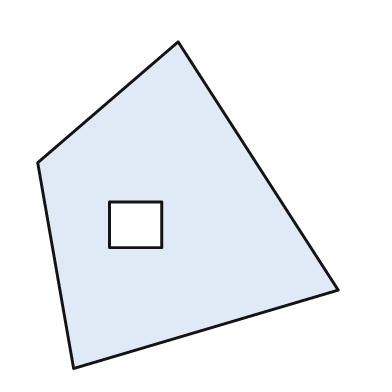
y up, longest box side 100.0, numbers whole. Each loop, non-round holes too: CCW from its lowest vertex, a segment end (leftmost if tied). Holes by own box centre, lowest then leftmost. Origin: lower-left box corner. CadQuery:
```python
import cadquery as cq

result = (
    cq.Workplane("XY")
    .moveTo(11.0, 0.0)
    .lineTo(92.0, 24.0)
    .lineTo(43.0, 100.0)
    .lineTo(0.0, 63.0)
    .close()
    .moveTo(22.0, 37.0)
    .lineTo(38.0, 37.0)
    .lineTo(38.0, 51.0)
    .lineTo(22.0, 51.0)
    .close()
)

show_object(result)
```